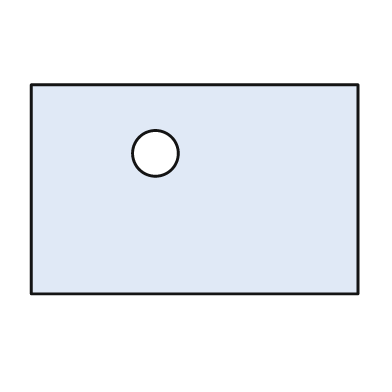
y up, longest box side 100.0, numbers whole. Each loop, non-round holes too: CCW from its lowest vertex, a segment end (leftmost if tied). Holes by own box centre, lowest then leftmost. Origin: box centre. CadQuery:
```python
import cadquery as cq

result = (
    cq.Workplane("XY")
    .moveTo(-50.0, -32.0)
    .lineTo(50.0, -32.0)
    .lineTo(50.0, 32.0)
    .lineTo(-50.0, 32.0)
    .close()
    .moveTo(-12.0, 11.0)
    .circle(7.0)
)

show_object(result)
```